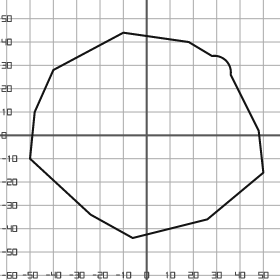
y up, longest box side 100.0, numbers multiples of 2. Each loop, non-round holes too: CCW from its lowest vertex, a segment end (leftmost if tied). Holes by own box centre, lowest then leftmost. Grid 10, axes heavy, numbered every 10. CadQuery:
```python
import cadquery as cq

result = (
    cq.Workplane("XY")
    .moveTo(-6.0, -44.0)
    .lineTo(26.0, -36.0)
    .lineTo(50.0, -16.0)
    .lineTo(48.0, 2.0)
    .lineTo(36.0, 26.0)
    .threePointArc((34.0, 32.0), (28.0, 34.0))
    .lineTo(18.0, 40.0)
    .lineTo(-10.0, 44.0)
    .lineTo(-40.0, 28.0)
    .lineTo(-48.0, 10.0)
    .lineTo(-50.0, -10.0)
    .lineTo(-24.0, -34.0)
    .close()
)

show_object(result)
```